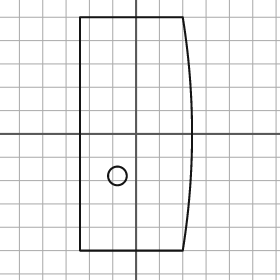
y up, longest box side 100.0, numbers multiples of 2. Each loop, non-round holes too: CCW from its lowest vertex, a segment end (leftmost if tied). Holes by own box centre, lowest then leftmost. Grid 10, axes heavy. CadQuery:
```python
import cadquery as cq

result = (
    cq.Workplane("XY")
    .moveTo(-24.0, -50.0)
    .lineTo(20.0, -50.0)
    .threePointArc((24.0, 0.0), (20.0, 50.0))
    .lineTo(-24.0, 50.0)
    .close()
    .moveTo(-8.0, -18.0)
    .circle(4.0)
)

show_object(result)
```